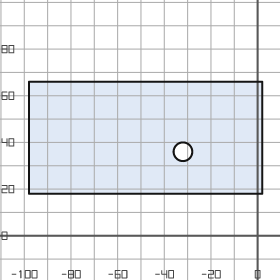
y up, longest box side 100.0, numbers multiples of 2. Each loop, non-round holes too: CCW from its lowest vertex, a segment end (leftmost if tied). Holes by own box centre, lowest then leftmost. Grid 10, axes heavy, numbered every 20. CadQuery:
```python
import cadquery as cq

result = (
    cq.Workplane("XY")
    .moveTo(-98.0, 18.0)
    .lineTo(2.0, 18.0)
    .lineTo(2.0, 66.0)
    .lineTo(-98.0, 66.0)
    .close()
    .moveTo(-32.0, 36.0)
    .circle(4.0)
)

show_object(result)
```